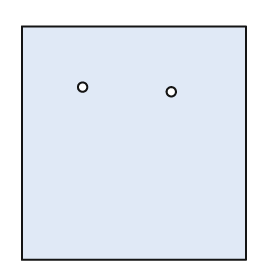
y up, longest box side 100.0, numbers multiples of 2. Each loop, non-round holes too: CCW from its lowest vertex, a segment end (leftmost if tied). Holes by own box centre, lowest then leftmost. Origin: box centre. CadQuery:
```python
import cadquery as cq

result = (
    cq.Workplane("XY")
    .moveTo(-48.0, -50.0)
    .lineTo(48.0, -50.0)
    .lineTo(48.0, 50.0)
    .lineTo(-48.0, 50.0)
    .close()
    .moveTo(16.0, 22.0)
    .circle(2.0)
    .moveTo(-22.0, 24.0)
    .circle(2.0)
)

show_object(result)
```